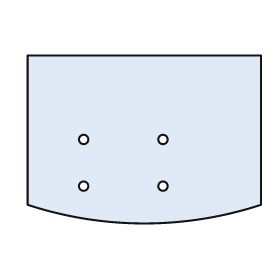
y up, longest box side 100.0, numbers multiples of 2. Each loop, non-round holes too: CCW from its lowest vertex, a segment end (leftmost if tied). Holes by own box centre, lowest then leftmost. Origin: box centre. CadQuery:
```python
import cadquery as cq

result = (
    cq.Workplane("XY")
    .moveTo(-50.0, -28.0)
    .threePointArc((0.0, -36.0), (50.0, -28.0))
    .lineTo(50.0, 36.0)
    .lineTo(-50.0, 36.0)
    .close()
    .moveTo(-26.0, -20.0)
    .circle(2.0)
    .moveTo(8.0, -20.0)
    .circle(2.0)
    .moveTo(-26.0, 0.0)
    .circle(2.0)
    .moveTo(8.0, 0.0)
    .circle(2.0)
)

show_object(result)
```